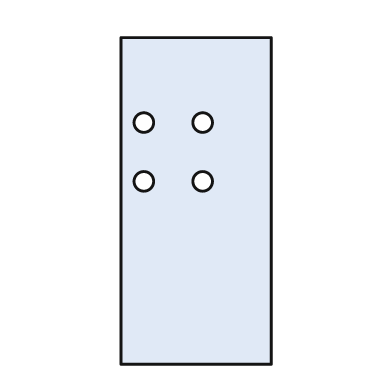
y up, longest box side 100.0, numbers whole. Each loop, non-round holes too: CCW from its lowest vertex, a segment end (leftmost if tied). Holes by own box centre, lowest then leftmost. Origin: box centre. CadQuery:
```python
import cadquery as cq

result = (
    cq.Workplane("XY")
    .moveTo(-23.0, -50.0)
    .lineTo(23.0, -50.0)
    .lineTo(23.0, 50.0)
    .lineTo(-23.0, 50.0)
    .close()
    .moveTo(-16.0, 6.0)
    .circle(3.0)
    .moveTo(2.0, 6.0)
    .circle(3.0)
    .moveTo(-16.0, 24.0)
    .circle(3.0)
    .moveTo(2.0, 24.0)
    .circle(3.0)
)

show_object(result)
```